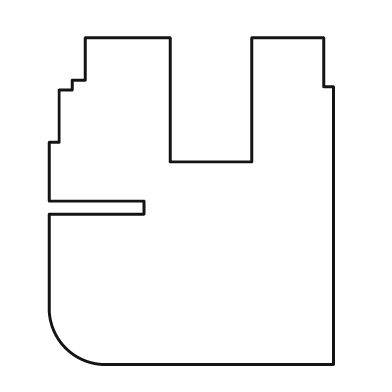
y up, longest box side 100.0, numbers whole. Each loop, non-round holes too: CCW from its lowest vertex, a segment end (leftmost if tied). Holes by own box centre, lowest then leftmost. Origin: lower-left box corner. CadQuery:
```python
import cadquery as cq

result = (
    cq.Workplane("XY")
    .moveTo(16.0, 0.0)
    .lineTo(87.0, 0.0)
    .lineTo(87.0, 85.0)
    .lineTo(84.0, 85.0)
    .lineTo(84.0, 100.0)
    .lineTo(62.0, 100.0)
    .lineTo(62.0, 62.0)
    .lineTo(37.0, 62.0)
    .lineTo(37.0, 100.0)
    .lineTo(11.0, 100.0)
    .lineTo(11.0, 87.0)
    .lineTo(7.0, 87.0)
    .lineTo(7.0, 84.0)
    .lineTo(3.0, 84.0)
    .lineTo(3.0, 68.0)
    .lineTo(0.0, 68.0)
    .lineTo(0.0, 50.0)
    .lineTo(29.0, 50.0)
    .lineTo(29.0, 46.0)
    .lineTo(0.0, 46.0)
    .lineTo(0.0, 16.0)
    .threePointArc((5.0, 5.0), (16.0, 0.0))
    .close()
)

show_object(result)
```